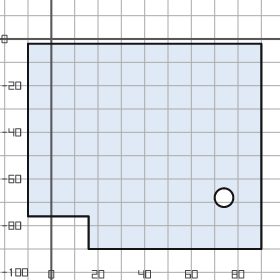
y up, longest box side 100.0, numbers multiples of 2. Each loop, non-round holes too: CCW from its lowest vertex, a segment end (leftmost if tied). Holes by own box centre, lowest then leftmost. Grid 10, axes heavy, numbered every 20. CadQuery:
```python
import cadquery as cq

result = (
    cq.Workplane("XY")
    .moveTo(16.0, -90.0)
    .lineTo(90.0, -90.0)
    .lineTo(90.0, -2.0)
    .lineTo(-10.0, -2.0)
    .lineTo(-10.0, -76.0)
    .lineTo(16.0, -76.0)
    .close()
    .moveTo(74.0, -68.0)
    .circle(4.0)
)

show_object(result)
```